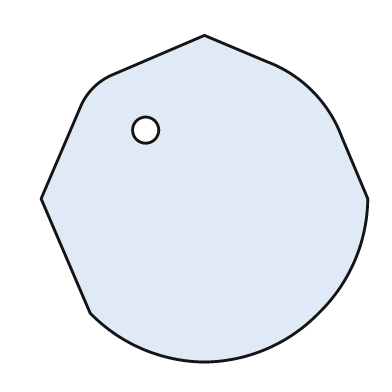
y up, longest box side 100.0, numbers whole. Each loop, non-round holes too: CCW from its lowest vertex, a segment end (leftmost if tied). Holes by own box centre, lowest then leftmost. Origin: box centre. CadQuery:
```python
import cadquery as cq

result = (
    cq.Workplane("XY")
    .moveTo(0.0, -50.0)
    .threePointArc((19.0, -46.0), (35.0, -35.0))
    .threePointArc((46.0, -19.0), (50.0, 0.0))
    .lineTo(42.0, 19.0)
    .threePointArc((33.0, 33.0), (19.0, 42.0))
    .lineTo(0.0, 50.0)
    .lineTo(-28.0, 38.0)
    .threePointArc((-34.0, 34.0), (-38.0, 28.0))
    .lineTo(-50.0, 0.0)
    .lineTo(-35.0, -35.0)
    .threePointArc((-19.0, -46.0), (0.0, -50.0))
    .close()
    .moveTo(-18.0, 21.0)
    .circle(4.0)
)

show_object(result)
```